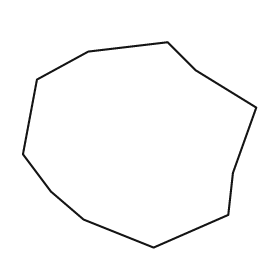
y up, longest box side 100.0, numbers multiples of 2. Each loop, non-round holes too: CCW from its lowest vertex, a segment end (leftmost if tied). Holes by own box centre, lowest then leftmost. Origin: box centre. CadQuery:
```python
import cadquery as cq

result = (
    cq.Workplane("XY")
    .moveTo(6.0, -44.0)
    .lineTo(38.0, -30.0)
    .lineTo(40.0, -12.0)
    .lineTo(50.0, 16.0)
    .lineTo(24.0, 32.0)
    .lineTo(12.0, 44.0)
    .lineTo(-22.0, 40.0)
    .lineTo(-44.0, 28.0)
    .lineTo(-50.0, -4.0)
    .lineTo(-38.0, -20.0)
    .lineTo(-24.0, -32.0)
    .close()
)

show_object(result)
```